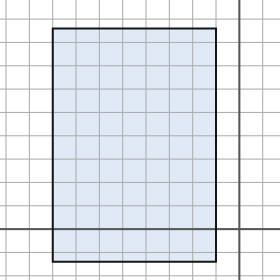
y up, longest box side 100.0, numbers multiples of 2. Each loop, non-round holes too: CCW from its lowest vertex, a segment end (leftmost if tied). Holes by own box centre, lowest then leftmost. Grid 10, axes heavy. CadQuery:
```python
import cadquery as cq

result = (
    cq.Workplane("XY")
    .moveTo(-80.0, -14.0)
    .lineTo(-10.0, -14.0)
    .lineTo(-10.0, 86.0)
    .lineTo(-80.0, 86.0)
    .close()
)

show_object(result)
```